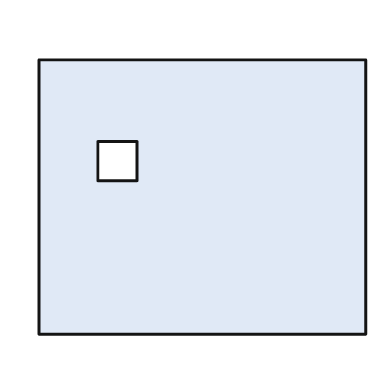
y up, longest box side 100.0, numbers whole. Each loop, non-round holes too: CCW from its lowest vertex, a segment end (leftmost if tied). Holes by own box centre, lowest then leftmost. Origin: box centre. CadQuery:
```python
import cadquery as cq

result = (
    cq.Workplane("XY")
    .moveTo(-50.0, -42.0)
    .lineTo(50.0, -42.0)
    .lineTo(50.0, 42.0)
    .lineTo(-50.0, 42.0)
    .close()
    .moveTo(-32.0, 5.0)
    .lineTo(-20.0, 5.0)
    .lineTo(-20.0, 17.0)
    .lineTo(-32.0, 17.0)
    .close()
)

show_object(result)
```